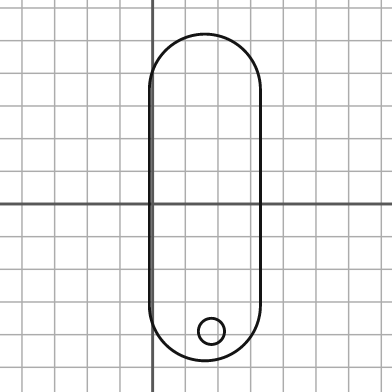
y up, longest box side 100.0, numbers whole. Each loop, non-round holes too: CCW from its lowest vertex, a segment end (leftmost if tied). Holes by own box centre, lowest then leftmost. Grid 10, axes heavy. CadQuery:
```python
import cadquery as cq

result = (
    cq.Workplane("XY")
    .moveTo(-1.0, -31.0)
    .threePointArc((16.0, -48.0), (33.0, -31.0))
    .lineTo(33.0, 35.0)
    .threePointArc((16.0, 52.0), (-1.0, 35.0))
    .close()
    .moveTo(18.0, -39.0)
    .circle(4.0)
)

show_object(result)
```